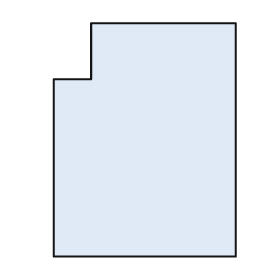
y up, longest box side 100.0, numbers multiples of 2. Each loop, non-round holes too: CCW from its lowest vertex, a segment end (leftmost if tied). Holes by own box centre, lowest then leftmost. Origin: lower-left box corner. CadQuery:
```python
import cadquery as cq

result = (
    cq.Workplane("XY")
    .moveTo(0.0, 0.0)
    .lineTo(78.0, 0.0)
    .lineTo(78.0, 100.0)
    .lineTo(16.0, 100.0)
    .lineTo(16.0, 76.0)
    .lineTo(0.0, 76.0)
    .close()
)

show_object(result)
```